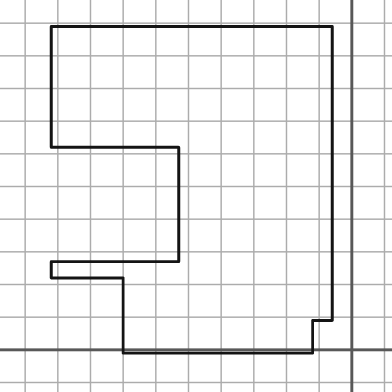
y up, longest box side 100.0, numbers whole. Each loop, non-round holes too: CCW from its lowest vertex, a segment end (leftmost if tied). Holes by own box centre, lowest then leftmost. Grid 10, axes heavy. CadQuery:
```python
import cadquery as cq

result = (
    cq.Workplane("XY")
    .moveTo(-70.0, -1.0)
    .lineTo(-12.0, -1.0)
    .lineTo(-12.0, 9.0)
    .lineTo(-6.0, 9.0)
    .lineTo(-6.0, 99.0)
    .lineTo(-92.0, 99.0)
    .lineTo(-92.0, 62.0)
    .lineTo(-53.0, 62.0)
    .lineTo(-53.0, 27.0)
    .lineTo(-92.0, 27.0)
    .lineTo(-92.0, 22.0)
    .lineTo(-70.0, 22.0)
    .close()
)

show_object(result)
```